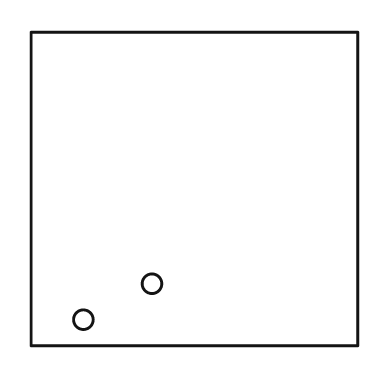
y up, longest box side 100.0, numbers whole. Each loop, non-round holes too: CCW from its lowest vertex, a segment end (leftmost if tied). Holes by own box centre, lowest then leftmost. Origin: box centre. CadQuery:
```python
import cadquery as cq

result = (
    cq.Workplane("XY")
    .moveTo(-50.0, -48.0)
    .lineTo(50.0, -48.0)
    .lineTo(50.0, 48.0)
    .lineTo(-50.0, 48.0)
    .close()
    .moveTo(-34.0, -40.0)
    .circle(3.0)
    .moveTo(-13.0, -29.0)
    .circle(3.0)
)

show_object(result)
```